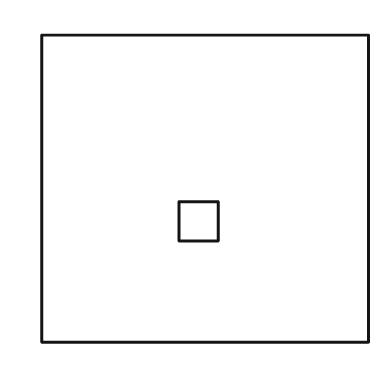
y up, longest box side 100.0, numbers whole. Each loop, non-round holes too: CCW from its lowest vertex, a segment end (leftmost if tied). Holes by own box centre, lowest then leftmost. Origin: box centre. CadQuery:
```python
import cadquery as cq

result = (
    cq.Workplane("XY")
    .moveTo(-50.0, -47.0)
    .lineTo(50.0, -47.0)
    .lineTo(50.0, 47.0)
    .lineTo(-50.0, 47.0)
    .close()
    .moveTo(-8.0, -16.0)
    .lineTo(4.0, -16.0)
    .lineTo(4.0, -4.0)
    .lineTo(-8.0, -4.0)
    .close()
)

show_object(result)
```